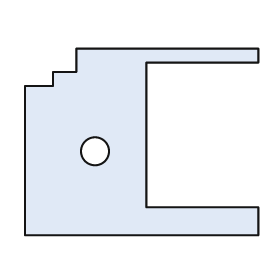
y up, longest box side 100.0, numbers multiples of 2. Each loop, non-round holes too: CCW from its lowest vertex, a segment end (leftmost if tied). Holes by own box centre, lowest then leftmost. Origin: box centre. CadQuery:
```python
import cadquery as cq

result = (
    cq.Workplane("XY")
    .moveTo(-50.0, -40.0)
    .lineTo(50.0, -40.0)
    .lineTo(50.0, -28.0)
    .lineTo(2.0, -28.0)
    .lineTo(2.0, 34.0)
    .lineTo(50.0, 34.0)
    .lineTo(50.0, 40.0)
    .lineTo(-28.0, 40.0)
    .lineTo(-28.0, 30.0)
    .lineTo(-38.0, 30.0)
    .lineTo(-38.0, 24.0)
    .lineTo(-50.0, 24.0)
    .close()
    .moveTo(-20.0, -4.0)
    .circle(6.0)
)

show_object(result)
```